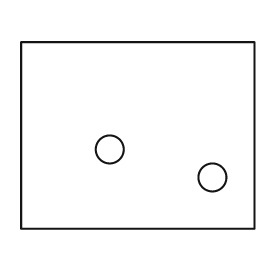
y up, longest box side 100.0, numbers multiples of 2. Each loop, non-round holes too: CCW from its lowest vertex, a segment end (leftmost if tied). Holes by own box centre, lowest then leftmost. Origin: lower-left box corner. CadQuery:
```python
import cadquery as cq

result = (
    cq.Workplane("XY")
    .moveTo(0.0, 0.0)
    .lineTo(100.0, 0.0)
    .lineTo(100.0, 80.0)
    .lineTo(0.0, 80.0)
    .close()
    .moveTo(82.0, 22.0)
    .circle(6.0)
    .moveTo(38.0, 34.0)
    .circle(6.0)
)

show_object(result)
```